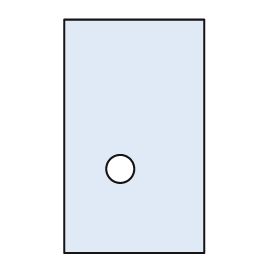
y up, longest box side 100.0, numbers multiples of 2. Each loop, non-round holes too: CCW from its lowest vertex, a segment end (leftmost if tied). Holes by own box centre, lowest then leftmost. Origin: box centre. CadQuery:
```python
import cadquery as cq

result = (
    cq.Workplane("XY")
    .moveTo(-30.0, -50.0)
    .lineTo(30.0, -50.0)
    .lineTo(30.0, 50.0)
    .lineTo(-30.0, 50.0)
    .close()
    .moveTo(-6.0, -14.0)
    .circle(6.0)
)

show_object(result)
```